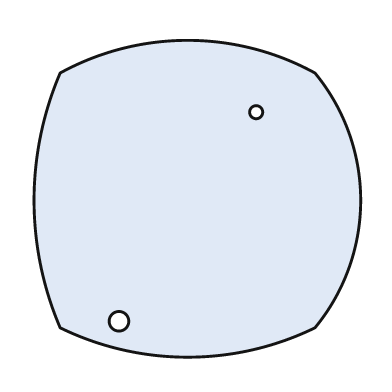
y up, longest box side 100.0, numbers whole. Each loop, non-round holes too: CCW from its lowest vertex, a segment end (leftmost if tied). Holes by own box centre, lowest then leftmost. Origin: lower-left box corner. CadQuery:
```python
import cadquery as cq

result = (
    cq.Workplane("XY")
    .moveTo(8.0, 9.0)
    .threePointArc((47.0, 0.0), (86.0, 9.0))
    .threePointArc((100.0, 48.0), (86.0, 87.0))
    .threePointArc((47.0, 97.0), (8.0, 87.0))
    .threePointArc((0.0, 48.0), (8.0, 9.0))
    .close()
    .moveTo(26.0, 11.0)
    .circle(3.0)
    .moveTo(68.0, 75.0)
    .circle(2.0)
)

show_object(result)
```